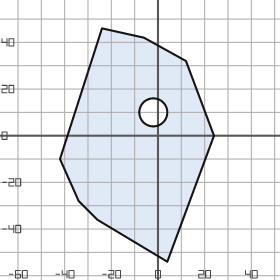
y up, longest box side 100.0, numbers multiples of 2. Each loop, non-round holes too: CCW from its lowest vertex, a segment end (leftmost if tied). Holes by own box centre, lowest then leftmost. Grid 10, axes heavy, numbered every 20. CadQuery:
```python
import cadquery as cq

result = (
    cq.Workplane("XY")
    .moveTo(4.0, -54.0)
    .lineTo(24.0, 0.0)
    .lineTo(12.0, 32.0)
    .lineTo(-6.0, 42.0)
    .lineTo(-24.0, 46.0)
    .lineTo(-42.0, -10.0)
    .lineTo(-34.0, -28.0)
    .lineTo(-26.0, -36.0)
    .close()
    .moveTo(-2.0, 10.0)
    .circle(6.0)
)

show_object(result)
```